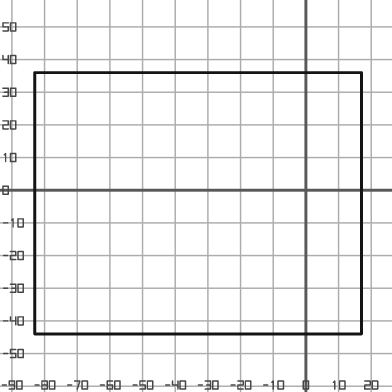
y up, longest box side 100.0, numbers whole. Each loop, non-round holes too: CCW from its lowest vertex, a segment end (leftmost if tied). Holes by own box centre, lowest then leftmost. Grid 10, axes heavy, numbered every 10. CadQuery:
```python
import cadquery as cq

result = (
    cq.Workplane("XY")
    .moveTo(-83.0, -44.0)
    .lineTo(17.0, -44.0)
    .lineTo(17.0, 36.0)
    .lineTo(-83.0, 36.0)
    .close()
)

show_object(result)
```